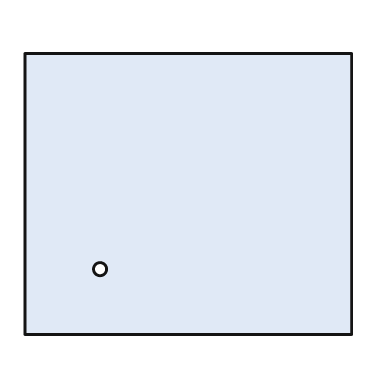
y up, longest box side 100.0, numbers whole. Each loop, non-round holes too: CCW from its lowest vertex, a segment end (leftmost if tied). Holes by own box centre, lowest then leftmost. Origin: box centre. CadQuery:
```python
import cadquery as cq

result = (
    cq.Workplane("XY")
    .moveTo(-50.0, -43.0)
    .lineTo(50.0, -43.0)
    .lineTo(50.0, 43.0)
    .lineTo(-50.0, 43.0)
    .close()
    .moveTo(-27.0, -23.0)
    .circle(2.0)
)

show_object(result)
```